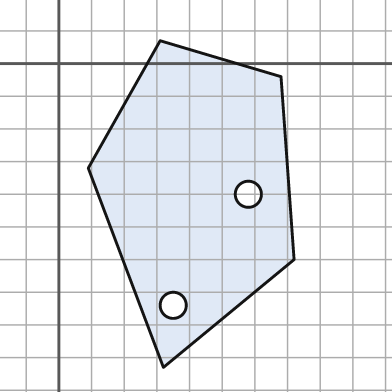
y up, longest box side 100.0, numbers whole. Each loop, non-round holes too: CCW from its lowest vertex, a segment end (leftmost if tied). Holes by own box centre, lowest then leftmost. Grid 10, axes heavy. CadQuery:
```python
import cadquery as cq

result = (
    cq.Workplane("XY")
    .moveTo(32.0, -93.0)
    .lineTo(72.0, -60.0)
    .lineTo(68.0, -4.0)
    .lineTo(31.0, 7.0)
    .lineTo(9.0, -32.0)
    .close()
    .moveTo(35.0, -74.0)
    .circle(4.0)
    .moveTo(58.0, -40.0)
    .circle(4.0)
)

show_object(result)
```